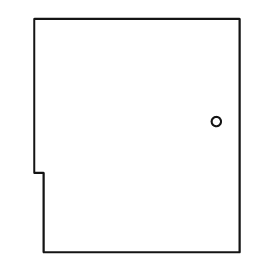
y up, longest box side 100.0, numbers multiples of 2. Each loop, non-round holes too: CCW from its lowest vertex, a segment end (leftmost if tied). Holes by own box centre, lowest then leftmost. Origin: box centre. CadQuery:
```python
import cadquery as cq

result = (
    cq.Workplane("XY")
    .moveTo(-40.0, -50.0)
    .lineTo(44.0, -50.0)
    .lineTo(44.0, 50.0)
    .lineTo(-44.0, 50.0)
    .lineTo(-44.0, -16.0)
    .lineTo(-40.0, -16.0)
    .close()
    .moveTo(34.0, 6.0)
    .circle(2.0)
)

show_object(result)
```